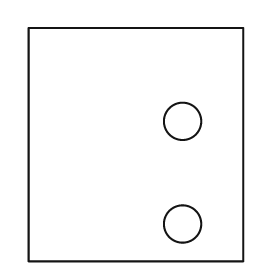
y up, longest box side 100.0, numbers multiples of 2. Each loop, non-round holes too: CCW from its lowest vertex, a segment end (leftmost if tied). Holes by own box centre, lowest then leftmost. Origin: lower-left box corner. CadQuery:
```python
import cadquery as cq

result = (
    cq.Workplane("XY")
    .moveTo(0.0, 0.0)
    .lineTo(92.0, 0.0)
    .lineTo(92.0, 100.0)
    .lineTo(0.0, 100.0)
    .close()
    .moveTo(66.0, 16.0)
    .circle(8.0)
    .moveTo(66.0, 60.0)
    .circle(8.0)
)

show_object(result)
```